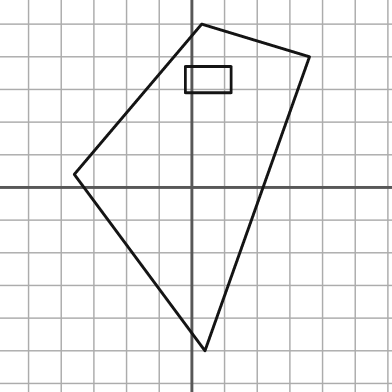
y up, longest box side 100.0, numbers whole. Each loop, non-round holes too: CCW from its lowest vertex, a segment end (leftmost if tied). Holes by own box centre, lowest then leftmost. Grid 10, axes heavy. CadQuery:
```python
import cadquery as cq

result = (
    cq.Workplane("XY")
    .moveTo(4.0, -50.0)
    .lineTo(36.0, 40.0)
    .lineTo(3.0, 50.0)
    .lineTo(-36.0, 4.0)
    .close()
    .moveTo(-2.0, 29.0)
    .lineTo(12.0, 29.0)
    .lineTo(12.0, 37.0)
    .lineTo(-2.0, 37.0)
    .close()
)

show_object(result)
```